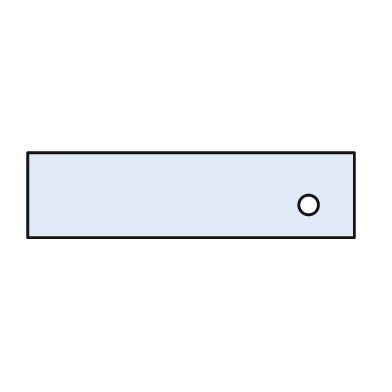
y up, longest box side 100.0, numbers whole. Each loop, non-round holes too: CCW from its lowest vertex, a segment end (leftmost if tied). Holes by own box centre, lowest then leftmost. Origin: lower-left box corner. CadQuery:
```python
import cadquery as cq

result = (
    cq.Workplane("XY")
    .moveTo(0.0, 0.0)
    .lineTo(100.0, 0.0)
    .lineTo(100.0, 26.0)
    .lineTo(0.0, 26.0)
    .close()
    .moveTo(86.0, 10.0)
    .circle(3.0)
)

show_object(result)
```